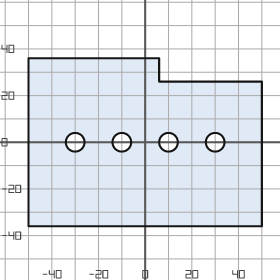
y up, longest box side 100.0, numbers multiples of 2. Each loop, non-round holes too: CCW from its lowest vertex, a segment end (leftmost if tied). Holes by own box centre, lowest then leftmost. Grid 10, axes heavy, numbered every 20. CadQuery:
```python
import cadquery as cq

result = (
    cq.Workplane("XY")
    .moveTo(-50.0, -36.0)
    .lineTo(50.0, -36.0)
    .lineTo(50.0, 26.0)
    .lineTo(6.0, 26.0)
    .lineTo(6.0, 36.0)
    .lineTo(-50.0, 36.0)
    .close()
    .moveTo(-30.0, 0.0)
    .circle(4.0)
    .moveTo(-10.0, 0.0)
    .circle(4.0)
    .moveTo(10.0, 0.0)
    .circle(4.0)
    .moveTo(30.0, 0.0)
    .circle(4.0)
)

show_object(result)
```